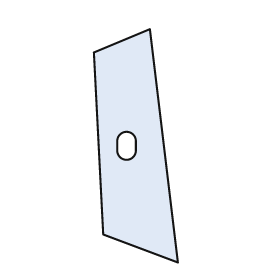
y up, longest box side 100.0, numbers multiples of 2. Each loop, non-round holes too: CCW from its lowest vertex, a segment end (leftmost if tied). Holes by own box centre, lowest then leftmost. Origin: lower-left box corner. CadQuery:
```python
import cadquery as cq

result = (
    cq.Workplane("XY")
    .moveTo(36.0, 0.0)
    .lineTo(24.0, 100.0)
    .lineTo(0.0, 90.0)
    .lineTo(4.0, 12.0)
    .close()
    .moveTo(10.0, 48.0)
    .threePointArc((14.0, 44.0), (18.0, 48.0))
    .lineTo(18.0, 52.0)
    .threePointArc((14.0, 56.0), (10.0, 52.0))
    .close()
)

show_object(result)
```